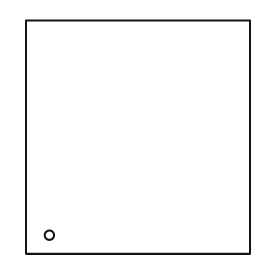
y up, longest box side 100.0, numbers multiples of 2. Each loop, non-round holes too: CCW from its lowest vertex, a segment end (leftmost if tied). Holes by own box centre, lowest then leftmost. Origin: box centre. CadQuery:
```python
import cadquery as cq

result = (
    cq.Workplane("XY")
    .moveTo(-48.0, -50.0)
    .lineTo(48.0, -50.0)
    .lineTo(48.0, 50.0)
    .lineTo(-48.0, 50.0)
    .close()
    .moveTo(-38.0, -42.0)
    .circle(2.0)
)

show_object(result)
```